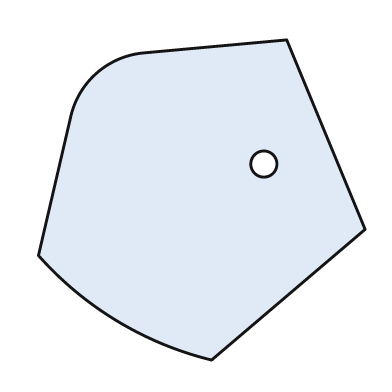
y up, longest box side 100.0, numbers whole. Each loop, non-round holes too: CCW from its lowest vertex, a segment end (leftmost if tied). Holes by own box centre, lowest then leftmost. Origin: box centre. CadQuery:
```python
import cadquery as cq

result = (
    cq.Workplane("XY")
    .moveTo(3.0, -49.0)
    .lineTo(50.0, -9.0)
    .lineTo(26.0, 49.0)
    .lineTo(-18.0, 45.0)
    .threePointArc((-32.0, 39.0), (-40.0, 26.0))
    .lineTo(-50.0, -17.0)
    .threePointArc((-26.0, -37.0), (3.0, -49.0))
    .close()
    .moveTo(19.0, 11.0)
    .circle(4.0)
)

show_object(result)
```